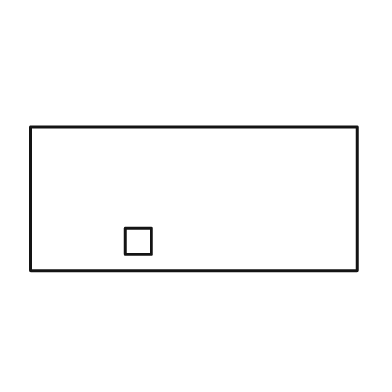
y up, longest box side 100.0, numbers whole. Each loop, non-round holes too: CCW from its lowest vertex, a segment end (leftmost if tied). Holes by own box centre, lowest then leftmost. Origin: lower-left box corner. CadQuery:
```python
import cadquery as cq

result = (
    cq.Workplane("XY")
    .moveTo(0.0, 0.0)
    .lineTo(100.0, 0.0)
    .lineTo(100.0, 44.0)
    .lineTo(0.0, 44.0)
    .close()
    .moveTo(29.0, 5.0)
    .lineTo(37.0, 5.0)
    .lineTo(37.0, 13.0)
    .lineTo(29.0, 13.0)
    .close()
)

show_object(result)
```